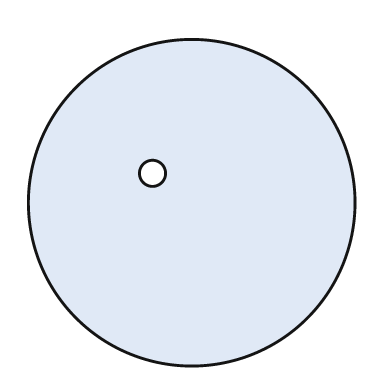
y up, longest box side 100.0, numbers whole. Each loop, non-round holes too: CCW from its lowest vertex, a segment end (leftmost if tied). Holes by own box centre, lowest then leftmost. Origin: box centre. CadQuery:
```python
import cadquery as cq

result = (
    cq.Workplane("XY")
    .moveTo(0.0, 0.0)
    .circle(50.0)
    .moveTo(-12.0, 9.0)
    .circle(4.0)
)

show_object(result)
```